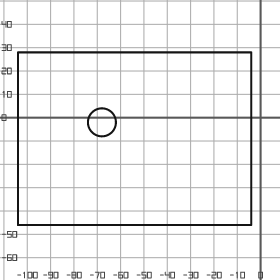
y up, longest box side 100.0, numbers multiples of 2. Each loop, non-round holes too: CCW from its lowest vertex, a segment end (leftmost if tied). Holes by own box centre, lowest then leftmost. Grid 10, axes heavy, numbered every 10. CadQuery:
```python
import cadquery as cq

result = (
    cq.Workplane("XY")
    .moveTo(-104.0, -46.0)
    .lineTo(-4.0, -46.0)
    .lineTo(-4.0, 28.0)
    .lineTo(-104.0, 28.0)
    .close()
    .moveTo(-68.0, -2.0)
    .circle(6.0)
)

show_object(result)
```